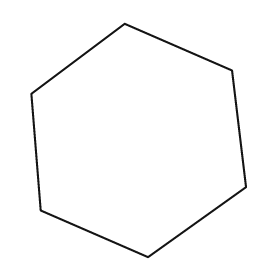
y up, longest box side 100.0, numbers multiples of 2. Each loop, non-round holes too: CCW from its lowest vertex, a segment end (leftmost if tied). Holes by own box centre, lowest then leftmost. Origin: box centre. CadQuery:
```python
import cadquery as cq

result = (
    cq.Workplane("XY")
    .moveTo(4.0, -50.0)
    .lineTo(46.0, -20.0)
    .lineTo(40.0, 30.0)
    .lineTo(-6.0, 50.0)
    .lineTo(-46.0, 20.0)
    .lineTo(-42.0, -30.0)
    .close()
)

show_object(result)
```